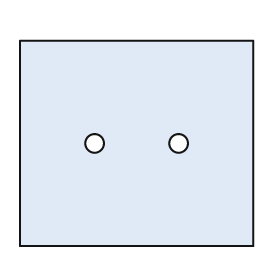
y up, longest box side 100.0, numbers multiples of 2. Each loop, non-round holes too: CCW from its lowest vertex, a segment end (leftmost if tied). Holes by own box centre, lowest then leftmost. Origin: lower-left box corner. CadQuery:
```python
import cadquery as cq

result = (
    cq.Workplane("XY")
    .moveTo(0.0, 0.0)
    .lineTo(100.0, 0.0)
    .lineTo(100.0, 88.0)
    .lineTo(0.0, 88.0)
    .close()
    .moveTo(32.0, 44.0)
    .circle(4.0)
    .moveTo(68.0, 44.0)
    .circle(4.0)
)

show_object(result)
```